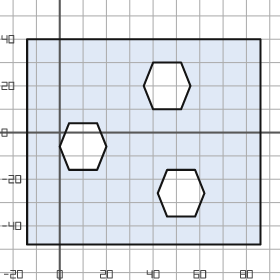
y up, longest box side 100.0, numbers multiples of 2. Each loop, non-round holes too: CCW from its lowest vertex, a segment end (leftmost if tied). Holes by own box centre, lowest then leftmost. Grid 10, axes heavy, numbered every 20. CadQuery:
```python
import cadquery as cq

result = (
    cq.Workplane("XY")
    .moveTo(-14.0, -48.0)
    .lineTo(86.0, -48.0)
    .lineTo(86.0, 40.0)
    .lineTo(-14.0, 40.0)
    .close()
    .moveTo(46.0, -36.0)
    .lineTo(58.0, -36.0)
    .lineTo(62.0, -26.0)
    .lineTo(58.0, -16.0)
    .lineTo(46.0, -16.0)
    .lineTo(42.0, -26.0)
    .close()
    .moveTo(4.0, -16.0)
    .lineTo(16.0, -16.0)
    .lineTo(20.0, -6.0)
    .lineTo(16.0, 4.0)
    .lineTo(4.0, 4.0)
    .lineTo(0.0, -6.0)
    .close()
    .moveTo(40.0, 10.0)
    .lineTo(52.0, 10.0)
    .lineTo(56.0, 20.0)
    .lineTo(52.0, 30.0)
    .lineTo(40.0, 30.0)
    .lineTo(36.0, 20.0)
    .close()
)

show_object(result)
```